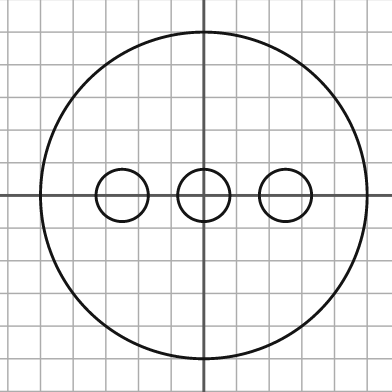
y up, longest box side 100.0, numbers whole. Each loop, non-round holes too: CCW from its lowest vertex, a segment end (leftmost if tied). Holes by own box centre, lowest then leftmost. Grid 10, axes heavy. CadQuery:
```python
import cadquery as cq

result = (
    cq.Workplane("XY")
    .moveTo(0.0, 0.0)
    .circle(50.0)
    .moveTo(-25.0, 0.0)
    .circle(8.0)
    .moveTo(0.0, 0.0)
    .circle(8.0)
    .moveTo(25.0, 0.0)
    .circle(8.0)
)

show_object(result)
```